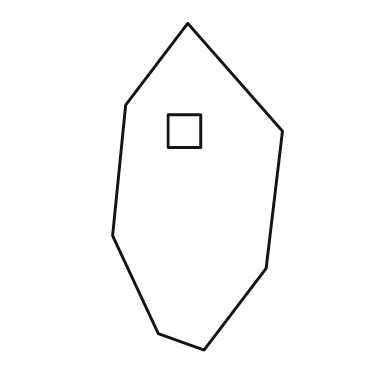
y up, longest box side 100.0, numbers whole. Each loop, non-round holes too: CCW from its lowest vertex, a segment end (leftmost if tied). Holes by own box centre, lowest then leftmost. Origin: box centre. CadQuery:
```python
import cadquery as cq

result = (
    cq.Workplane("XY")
    .moveTo(2.0, -50.0)
    .lineTo(21.0, -25.0)
    .lineTo(26.0, 17.0)
    .lineTo(-3.0, 50.0)
    .lineTo(-22.0, 25.0)
    .lineTo(-26.0, -15.0)
    .lineTo(-12.0, -45.0)
    .close()
    .moveTo(-9.0, 12.0)
    .lineTo(1.0, 12.0)
    .lineTo(1.0, 22.0)
    .lineTo(-9.0, 22.0)
    .close()
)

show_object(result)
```